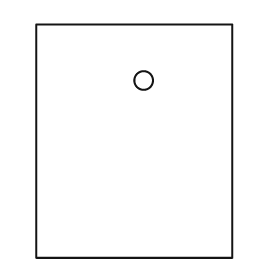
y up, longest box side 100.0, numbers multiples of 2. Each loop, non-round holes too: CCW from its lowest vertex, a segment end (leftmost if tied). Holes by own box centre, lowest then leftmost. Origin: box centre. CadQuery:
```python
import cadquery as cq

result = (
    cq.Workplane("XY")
    .moveTo(-42.0, -50.0)
    .lineTo(42.0, -50.0)
    .lineTo(42.0, 50.0)
    .lineTo(-42.0, 50.0)
    .close()
    .moveTo(4.0, 26.0)
    .circle(4.0)
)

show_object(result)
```